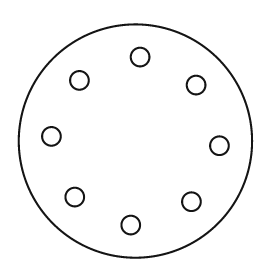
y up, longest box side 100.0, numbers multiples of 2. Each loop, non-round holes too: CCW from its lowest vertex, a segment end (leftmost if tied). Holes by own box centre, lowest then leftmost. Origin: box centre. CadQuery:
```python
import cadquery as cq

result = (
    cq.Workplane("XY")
    .moveTo(0.0, 0.0)
    .circle(50.0)
    .moveTo(-2.0, -36.0)
    .circle(4.0)
    .moveTo(24.0, -26.0)
    .circle(4.0)
    .moveTo(-26.0, -24.0)
    .circle(4.0)
    .moveTo(36.0, -2.0)
    .circle(4.0)
    .moveTo(-36.0, 2.0)
    .circle(4.0)
    .moveTo(26.0, 24.0)
    .circle(4.0)
    .moveTo(-24.0, 26.0)
    .circle(4.0)
    .moveTo(2.0, 36.0)
    .circle(4.0)
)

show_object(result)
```